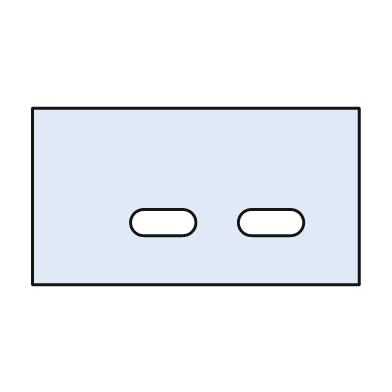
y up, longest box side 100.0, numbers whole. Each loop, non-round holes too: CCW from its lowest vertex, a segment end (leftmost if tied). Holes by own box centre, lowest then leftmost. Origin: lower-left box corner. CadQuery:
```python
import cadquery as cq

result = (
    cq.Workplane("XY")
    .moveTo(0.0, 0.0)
    .lineTo(100.0, 0.0)
    .lineTo(100.0, 54.0)
    .lineTo(0.0, 54.0)
    .close()
    .moveTo(34.0, 15.0)
    .lineTo(46.0, 15.0)
    .threePointArc((50.0, 19.0), (46.0, 23.0))
    .lineTo(34.0, 23.0)
    .threePointArc((30.0, 19.0), (34.0, 15.0))
    .close()
    .moveTo(67.0, 15.0)
    .lineTo(79.0, 15.0)
    .threePointArc((83.0, 19.0), (79.0, 23.0))
    .lineTo(67.0, 23.0)
    .threePointArc((63.0, 19.0), (67.0, 15.0))
    .close()
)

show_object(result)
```